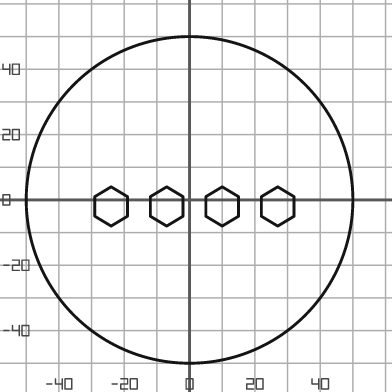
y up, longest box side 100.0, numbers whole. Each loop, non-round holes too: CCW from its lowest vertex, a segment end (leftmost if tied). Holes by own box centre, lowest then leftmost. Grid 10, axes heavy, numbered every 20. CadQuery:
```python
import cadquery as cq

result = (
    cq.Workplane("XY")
    .moveTo(0.0, 0.0)
    .circle(50.0)
    .moveTo(-24.0, -8.0)
    .lineTo(-19.0, -5.0)
    .lineTo(-19.0, 1.0)
    .lineTo(-24.0, 4.0)
    .lineTo(-29.0, 1.0)
    .lineTo(-29.0, -5.0)
    .close()
    .moveTo(-7.0, -8.0)
    .lineTo(-2.0, -5.0)
    .lineTo(-2.0, 1.0)
    .lineTo(-7.0, 4.0)
    .lineTo(-12.0, 1.0)
    .lineTo(-12.0, -5.0)
    .close()
    .moveTo(10.0, -8.0)
    .lineTo(15.0, -5.0)
    .lineTo(15.0, 1.0)
    .lineTo(10.0, 4.0)
    .lineTo(5.0, 1.0)
    .lineTo(5.0, -5.0)
    .close()
    .moveTo(27.0, -8.0)
    .lineTo(32.0, -5.0)
    .lineTo(32.0, 1.0)
    .lineTo(27.0, 4.0)
    .lineTo(22.0, 1.0)
    .lineTo(22.0, -5.0)
    .close()
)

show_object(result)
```